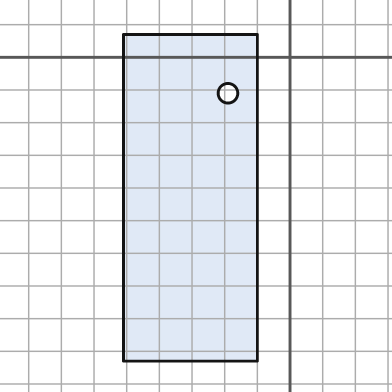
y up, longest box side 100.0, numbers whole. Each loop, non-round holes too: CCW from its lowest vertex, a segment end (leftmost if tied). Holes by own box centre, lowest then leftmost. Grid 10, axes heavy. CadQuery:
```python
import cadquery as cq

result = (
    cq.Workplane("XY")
    .moveTo(-51.0, -93.0)
    .lineTo(-10.0, -93.0)
    .lineTo(-10.0, 7.0)
    .lineTo(-51.0, 7.0)
    .close()
    .moveTo(-19.0, -11.0)
    .circle(3.0)
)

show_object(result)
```